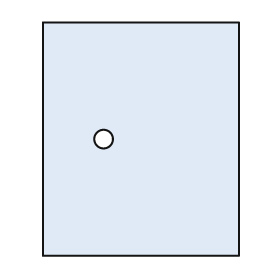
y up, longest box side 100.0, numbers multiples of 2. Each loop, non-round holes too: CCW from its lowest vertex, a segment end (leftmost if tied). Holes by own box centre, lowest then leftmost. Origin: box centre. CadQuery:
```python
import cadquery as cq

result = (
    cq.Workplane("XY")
    .moveTo(-42.0, -50.0)
    .lineTo(42.0, -50.0)
    .lineTo(42.0, 50.0)
    .lineTo(-42.0, 50.0)
    .close()
    .moveTo(-16.0, 0.0)
    .circle(4.0)
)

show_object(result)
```